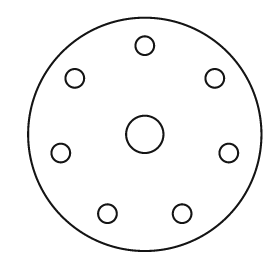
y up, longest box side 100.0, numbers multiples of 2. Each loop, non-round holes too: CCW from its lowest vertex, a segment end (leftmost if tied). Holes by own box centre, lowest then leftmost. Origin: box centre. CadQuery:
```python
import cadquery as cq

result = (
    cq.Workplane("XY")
    .moveTo(0.0, 0.0)
    .circle(50.0)
    .moveTo(-16.0, -34.0)
    .circle(4.0)
    .moveTo(16.0, -34.0)
    .circle(4.0)
    .moveTo(-36.0, -8.0)
    .circle(4.0)
    .moveTo(36.0, -8.0)
    .circle(4.0)
    .moveTo(0.0, 0.0)
    .circle(8.0)
    .moveTo(-30.0, 24.0)
    .circle(4.0)
    .moveTo(30.0, 24.0)
    .circle(4.0)
    .moveTo(0.0, 38.0)
    .circle(4.0)
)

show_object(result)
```